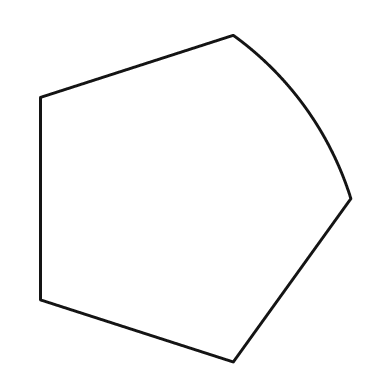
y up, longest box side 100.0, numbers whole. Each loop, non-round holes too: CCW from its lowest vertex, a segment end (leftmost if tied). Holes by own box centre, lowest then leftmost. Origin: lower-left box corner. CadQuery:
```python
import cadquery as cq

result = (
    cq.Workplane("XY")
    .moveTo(59.0, 0.0)
    .lineTo(95.0, 50.0)
    .threePointArc((81.0, 78.0), (59.0, 100.0))
    .lineTo(0.0, 81.0)
    .lineTo(0.0, 19.0)
    .close()
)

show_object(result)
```